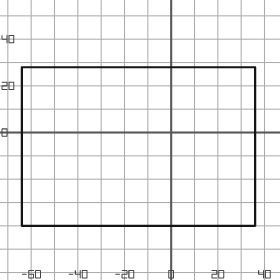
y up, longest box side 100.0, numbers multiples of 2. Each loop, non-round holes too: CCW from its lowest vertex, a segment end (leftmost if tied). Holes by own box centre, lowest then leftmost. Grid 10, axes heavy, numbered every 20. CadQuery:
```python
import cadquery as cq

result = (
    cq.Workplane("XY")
    .moveTo(-64.0, -40.0)
    .lineTo(36.0, -40.0)
    .lineTo(36.0, 28.0)
    .lineTo(-64.0, 28.0)
    .close()
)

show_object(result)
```